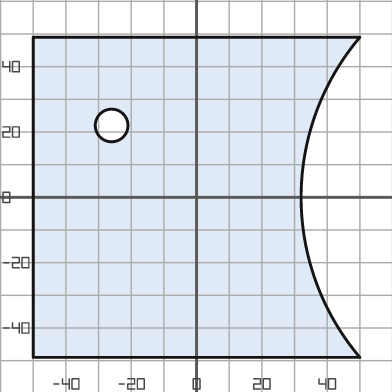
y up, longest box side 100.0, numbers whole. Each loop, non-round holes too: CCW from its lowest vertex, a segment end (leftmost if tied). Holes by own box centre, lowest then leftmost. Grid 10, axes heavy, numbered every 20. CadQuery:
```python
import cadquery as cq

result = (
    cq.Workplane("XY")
    .moveTo(-50.0, -49.0)
    .lineTo(50.0, -49.0)
    .threePointArc((32.0, 0.0), (50.0, 49.0))
    .lineTo(-50.0, 49.0)
    .close()
    .moveTo(-26.0, 22.0)
    .circle(5.0)
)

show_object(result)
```